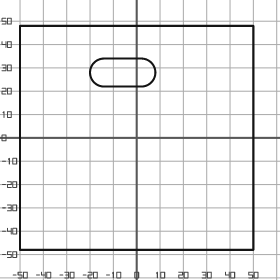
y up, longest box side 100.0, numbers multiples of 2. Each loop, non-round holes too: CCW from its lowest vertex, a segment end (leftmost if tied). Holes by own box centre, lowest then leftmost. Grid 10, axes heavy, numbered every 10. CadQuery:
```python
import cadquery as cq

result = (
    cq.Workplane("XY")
    .moveTo(-50.0, -48.0)
    .lineTo(50.0, -48.0)
    .lineTo(50.0, 48.0)
    .lineTo(-50.0, 48.0)
    .close()
    .moveTo(-14.0, 22.0)
    .lineTo(2.0, 22.0)
    .threePointArc((8.0, 28.0), (2.0, 34.0))
    .lineTo(-14.0, 34.0)
    .threePointArc((-20.0, 28.0), (-14.0, 22.0))
    .close()
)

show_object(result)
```